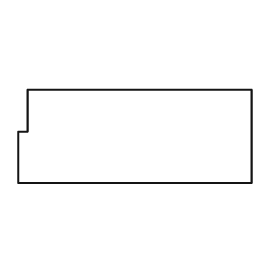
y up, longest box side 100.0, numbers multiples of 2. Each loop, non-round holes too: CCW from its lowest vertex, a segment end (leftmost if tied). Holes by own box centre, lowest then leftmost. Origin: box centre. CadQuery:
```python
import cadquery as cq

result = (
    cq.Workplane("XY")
    .moveTo(-50.0, -20.0)
    .lineTo(50.0, -20.0)
    .lineTo(50.0, 20.0)
    .lineTo(-46.0, 20.0)
    .lineTo(-46.0, 2.0)
    .lineTo(-50.0, 2.0)
    .close()
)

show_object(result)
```